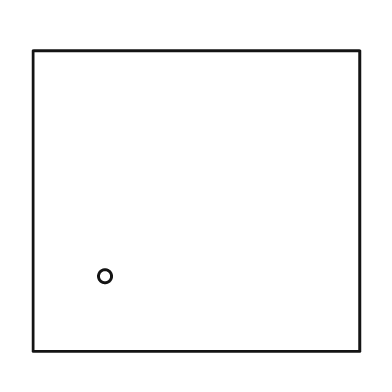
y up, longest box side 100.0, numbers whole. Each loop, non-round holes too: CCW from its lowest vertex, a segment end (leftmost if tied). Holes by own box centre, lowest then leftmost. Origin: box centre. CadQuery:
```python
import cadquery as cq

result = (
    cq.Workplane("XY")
    .moveTo(-50.0, -46.0)
    .lineTo(50.0, -46.0)
    .lineTo(50.0, 46.0)
    .lineTo(-50.0, 46.0)
    .close()
    .moveTo(-28.0, -23.0)
    .circle(2.0)
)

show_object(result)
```